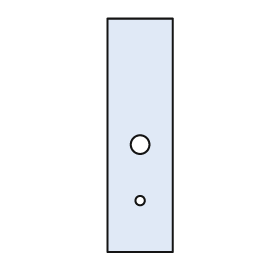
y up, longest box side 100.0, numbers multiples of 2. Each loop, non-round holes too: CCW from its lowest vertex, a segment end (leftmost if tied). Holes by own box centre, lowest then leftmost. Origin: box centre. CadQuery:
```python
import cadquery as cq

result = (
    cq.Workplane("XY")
    .moveTo(-14.0, -50.0)
    .lineTo(14.0, -50.0)
    .lineTo(14.0, 50.0)
    .lineTo(-14.0, 50.0)
    .close()
    .moveTo(0.0, -28.0)
    .circle(2.0)
    .moveTo(0.0, -4.0)
    .circle(4.0)
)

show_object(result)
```